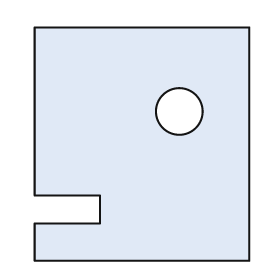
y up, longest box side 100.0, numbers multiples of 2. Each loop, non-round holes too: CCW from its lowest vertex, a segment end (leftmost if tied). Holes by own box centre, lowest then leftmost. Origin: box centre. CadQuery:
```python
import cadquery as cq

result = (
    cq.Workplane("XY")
    .moveTo(-46.0, -50.0)
    .lineTo(46.0, -50.0)
    .lineTo(46.0, 50.0)
    .lineTo(-46.0, 50.0)
    .lineTo(-46.0, -22.0)
    .lineTo(-18.0, -22.0)
    .lineTo(-18.0, -34.0)
    .lineTo(-46.0, -34.0)
    .close()
    .moveTo(16.0, 14.0)
    .circle(10.0)
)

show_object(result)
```